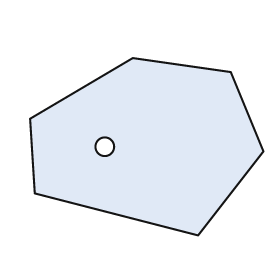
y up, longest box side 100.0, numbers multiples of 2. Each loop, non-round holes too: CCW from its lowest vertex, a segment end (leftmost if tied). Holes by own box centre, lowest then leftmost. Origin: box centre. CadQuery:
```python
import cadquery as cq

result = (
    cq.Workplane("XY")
    .moveTo(22.0, -38.0)
    .lineTo(50.0, -2.0)
    .lineTo(36.0, 32.0)
    .lineTo(-6.0, 38.0)
    .lineTo(-50.0, 12.0)
    .lineTo(-48.0, -20.0)
    .close()
    .moveTo(-18.0, 0.0)
    .circle(4.0)
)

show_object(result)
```